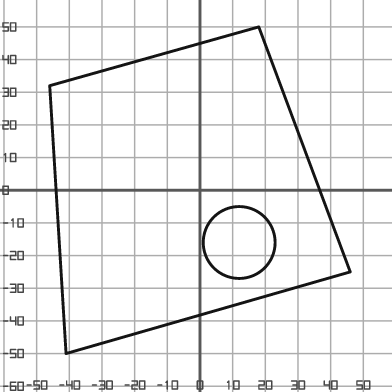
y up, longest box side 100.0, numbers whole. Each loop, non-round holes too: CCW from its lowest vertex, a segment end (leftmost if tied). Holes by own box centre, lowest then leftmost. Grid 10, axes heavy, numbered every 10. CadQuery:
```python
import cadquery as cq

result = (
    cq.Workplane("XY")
    .moveTo(-41.0, -50.0)
    .lineTo(46.0, -25.0)
    .lineTo(18.0, 50.0)
    .lineTo(-46.0, 32.0)
    .close()
    .moveTo(12.0, -16.0)
    .circle(11.0)
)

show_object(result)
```